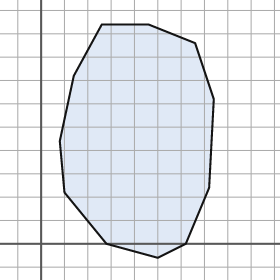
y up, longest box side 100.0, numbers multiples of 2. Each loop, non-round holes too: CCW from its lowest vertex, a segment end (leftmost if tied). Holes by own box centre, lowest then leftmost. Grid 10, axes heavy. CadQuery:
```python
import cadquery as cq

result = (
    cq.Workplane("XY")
    .moveTo(50.0, -6.0)
    .lineTo(62.0, 0.0)
    .lineTo(72.0, 24.0)
    .lineTo(74.0, 62.0)
    .lineTo(66.0, 86.0)
    .lineTo(46.0, 94.0)
    .lineTo(26.0, 94.0)
    .lineTo(14.0, 72.0)
    .lineTo(8.0, 44.0)
    .lineTo(10.0, 22.0)
    .lineTo(28.0, 0.0)
    .close()
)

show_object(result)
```